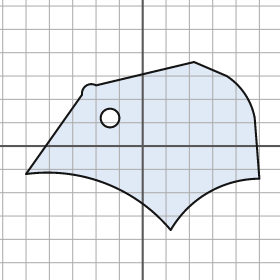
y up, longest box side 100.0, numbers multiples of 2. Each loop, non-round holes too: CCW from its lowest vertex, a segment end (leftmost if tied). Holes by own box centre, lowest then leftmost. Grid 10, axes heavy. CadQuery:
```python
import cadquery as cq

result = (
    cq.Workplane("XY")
    .moveTo(12.0, -36.0)
    .threePointArc((28.0, -20.0), (50.0, -14.0))
    .lineTo(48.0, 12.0)
    .threePointArc((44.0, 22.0), (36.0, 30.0))
    .lineTo(22.0, 36.0)
    .lineTo(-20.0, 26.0)
    .threePointArc((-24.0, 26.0), (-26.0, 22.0))
    .lineTo(-50.0, -12.0)
    .threePointArc((-16.0, -16.0), (12.0, -36.0))
    .close()
    .moveTo(-14.0, 12.0)
    .circle(4.0)
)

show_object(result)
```